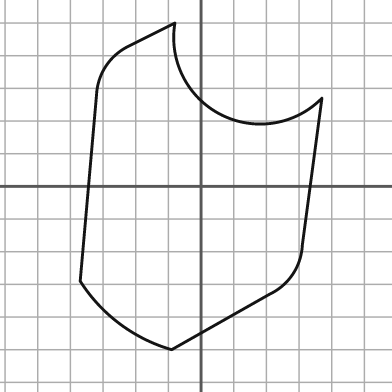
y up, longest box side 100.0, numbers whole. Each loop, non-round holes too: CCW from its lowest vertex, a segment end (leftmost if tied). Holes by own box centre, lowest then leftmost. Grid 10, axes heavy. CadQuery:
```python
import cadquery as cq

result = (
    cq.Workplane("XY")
    .moveTo(-9.0, -50.0)
    .lineTo(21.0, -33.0)
    .threePointArc((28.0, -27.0), (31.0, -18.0))
    .lineTo(37.0, 27.0)
    .threePointArc((6.0, 22.0), (-8.0, 50.0))
    .lineTo(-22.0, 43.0)
    .threePointArc((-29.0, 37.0), (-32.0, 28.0))
    .lineTo(-37.0, -29.0)
    .threePointArc((-25.0, -42.0), (-9.0, -50.0))
    .close()
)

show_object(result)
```